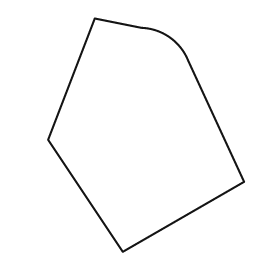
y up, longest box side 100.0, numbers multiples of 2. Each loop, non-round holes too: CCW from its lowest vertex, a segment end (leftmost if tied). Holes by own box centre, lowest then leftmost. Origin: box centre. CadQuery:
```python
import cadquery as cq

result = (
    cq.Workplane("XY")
    .moveTo(-10.0, -50.0)
    .lineTo(42.0, -20.0)
    .lineTo(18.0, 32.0)
    .threePointArc((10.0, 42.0), (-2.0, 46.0))
    .lineTo(-22.0, 50.0)
    .lineTo(-42.0, -2.0)
    .close()
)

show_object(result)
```